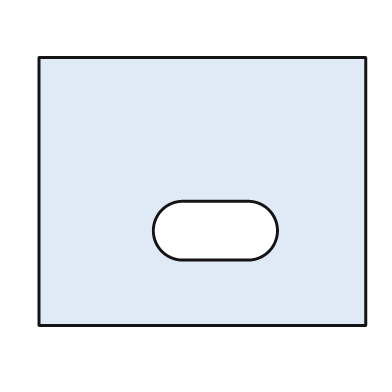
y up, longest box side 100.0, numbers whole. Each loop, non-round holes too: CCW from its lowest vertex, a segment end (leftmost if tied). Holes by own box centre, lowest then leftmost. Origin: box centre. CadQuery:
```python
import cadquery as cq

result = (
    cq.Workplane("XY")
    .moveTo(-50.0, -41.0)
    .lineTo(50.0, -41.0)
    .lineTo(50.0, 41.0)
    .lineTo(-50.0, 41.0)
    .close()
    .moveTo(-6.0, -21.0)
    .lineTo(14.0, -21.0)
    .threePointArc((23.0, -12.0), (14.0, -3.0))
    .lineTo(-6.0, -3.0)
    .threePointArc((-15.0, -12.0), (-6.0, -21.0))
    .close()
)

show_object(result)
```